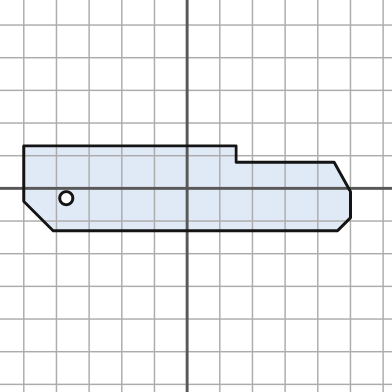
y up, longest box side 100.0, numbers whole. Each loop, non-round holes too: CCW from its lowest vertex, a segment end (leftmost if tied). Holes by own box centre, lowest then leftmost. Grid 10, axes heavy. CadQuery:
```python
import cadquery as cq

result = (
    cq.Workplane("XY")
    .moveTo(-41.0, -13.0)
    .lineTo(46.0, -13.0)
    .lineTo(50.0, -9.0)
    .lineTo(50.0, -1.0)
    .lineTo(45.0, 8.0)
    .lineTo(15.0, 8.0)
    .lineTo(15.0, 13.0)
    .lineTo(-50.0, 13.0)
    .lineTo(-50.0, -4.0)
    .close()
    .moveTo(-37.0, -3.0)
    .circle(2.0)
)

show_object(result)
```